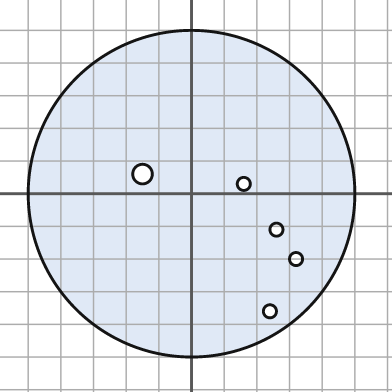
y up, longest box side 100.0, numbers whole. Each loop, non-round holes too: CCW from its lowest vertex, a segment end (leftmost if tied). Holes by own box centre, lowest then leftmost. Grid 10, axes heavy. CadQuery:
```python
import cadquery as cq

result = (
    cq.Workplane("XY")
    .moveTo(0.0, 0.0)
    .circle(50.0)
    .moveTo(24.0, -36.0)
    .circle(2.0)
    .moveTo(32.0, -20.0)
    .circle(2.0)
    .moveTo(26.0, -11.0)
    .circle(2.0)
    .moveTo(16.0, 3.0)
    .circle(2.0)
    .moveTo(-15.0, 6.0)
    .circle(3.0)
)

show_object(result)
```